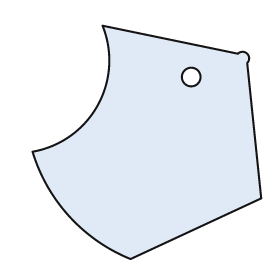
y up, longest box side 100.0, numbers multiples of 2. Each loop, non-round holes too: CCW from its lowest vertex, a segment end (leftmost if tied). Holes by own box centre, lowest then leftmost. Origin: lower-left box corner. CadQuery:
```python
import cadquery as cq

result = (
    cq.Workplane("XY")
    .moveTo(42.0, 0.0)
    .lineTo(98.0, 26.0)
    .lineTo(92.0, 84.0)
    .threePointArc((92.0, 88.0), (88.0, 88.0))
    .lineTo(30.0, 100.0)
    .threePointArc((28.0, 66.0), (0.0, 46.0))
    .threePointArc((16.0, 18.0), (42.0, 0.0))
    .close()
    .moveTo(68.0, 78.0)
    .circle(4.0)
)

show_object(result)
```